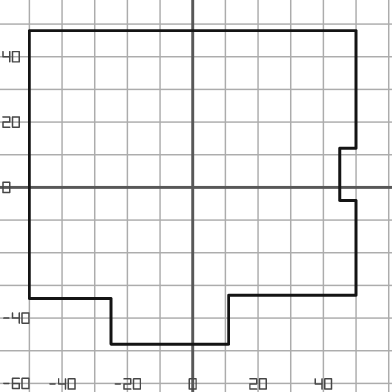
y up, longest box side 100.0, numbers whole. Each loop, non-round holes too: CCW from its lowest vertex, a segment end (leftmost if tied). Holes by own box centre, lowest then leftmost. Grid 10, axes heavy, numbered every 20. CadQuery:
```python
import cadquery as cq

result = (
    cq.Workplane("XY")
    .moveTo(-25.0, -48.0)
    .lineTo(11.0, -48.0)
    .lineTo(11.0, -33.0)
    .lineTo(50.0, -33.0)
    .lineTo(50.0, -4.0)
    .lineTo(45.0, -4.0)
    .lineTo(45.0, 12.0)
    .lineTo(50.0, 12.0)
    .lineTo(50.0, 48.0)
    .lineTo(-50.0, 48.0)
    .lineTo(-50.0, -34.0)
    .lineTo(-25.0, -34.0)
    .close()
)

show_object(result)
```